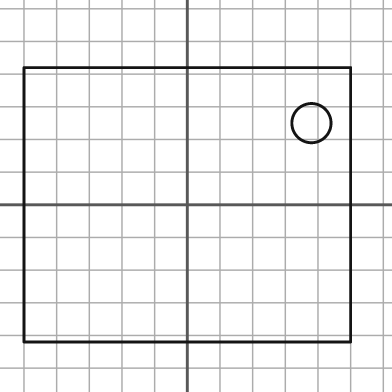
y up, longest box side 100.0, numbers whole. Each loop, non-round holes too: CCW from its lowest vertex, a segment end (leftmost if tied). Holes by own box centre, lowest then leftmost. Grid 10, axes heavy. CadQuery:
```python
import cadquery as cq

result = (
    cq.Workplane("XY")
    .moveTo(-50.0, -42.0)
    .lineTo(50.0, -42.0)
    .lineTo(50.0, 42.0)
    .lineTo(-50.0, 42.0)
    .close()
    .moveTo(38.0, 25.0)
    .circle(6.0)
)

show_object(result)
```